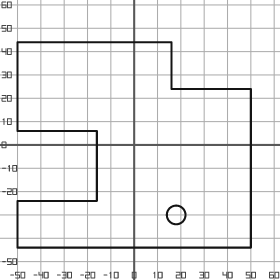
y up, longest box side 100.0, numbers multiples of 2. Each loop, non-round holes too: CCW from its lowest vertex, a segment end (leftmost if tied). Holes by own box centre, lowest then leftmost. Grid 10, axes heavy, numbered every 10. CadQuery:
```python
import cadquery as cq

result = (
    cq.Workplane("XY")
    .moveTo(-50.0, -44.0)
    .lineTo(50.0, -44.0)
    .lineTo(50.0, 24.0)
    .lineTo(16.0, 24.0)
    .lineTo(16.0, 44.0)
    .lineTo(-50.0, 44.0)
    .lineTo(-50.0, 6.0)
    .lineTo(-16.0, 6.0)
    .lineTo(-16.0, -24.0)
    .lineTo(-50.0, -24.0)
    .close()
    .moveTo(18.0, -30.0)
    .circle(4.0)
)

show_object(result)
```